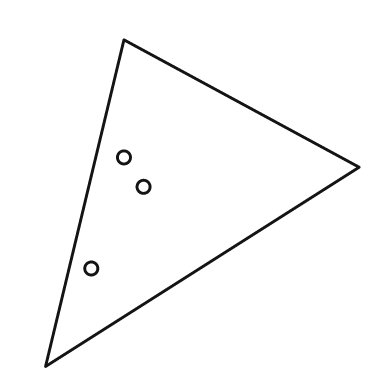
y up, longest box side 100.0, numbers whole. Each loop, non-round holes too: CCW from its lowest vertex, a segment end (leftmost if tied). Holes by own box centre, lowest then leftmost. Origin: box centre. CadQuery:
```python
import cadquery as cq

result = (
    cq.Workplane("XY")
    .moveTo(-48.0, -50.0)
    .lineTo(48.0, 11.0)
    .lineTo(-24.0, 50.0)
    .close()
    .moveTo(-34.0, -20.0)
    .circle(2.0)
    .moveTo(-18.0, 5.0)
    .circle(2.0)
    .moveTo(-24.0, 14.0)
    .circle(2.0)
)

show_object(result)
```